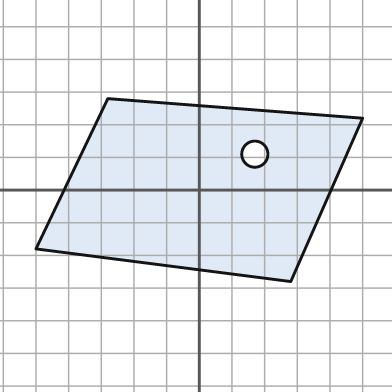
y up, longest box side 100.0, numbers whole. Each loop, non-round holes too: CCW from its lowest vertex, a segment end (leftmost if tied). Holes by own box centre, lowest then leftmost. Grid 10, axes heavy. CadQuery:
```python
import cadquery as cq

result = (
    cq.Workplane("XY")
    .moveTo(28.0, -28.0)
    .lineTo(50.0, 22.0)
    .lineTo(-28.0, 28.0)
    .lineTo(-50.0, -18.0)
    .close()
    .moveTo(17.0, 11.0)
    .circle(4.0)
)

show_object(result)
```